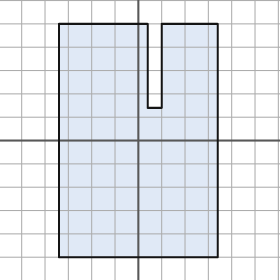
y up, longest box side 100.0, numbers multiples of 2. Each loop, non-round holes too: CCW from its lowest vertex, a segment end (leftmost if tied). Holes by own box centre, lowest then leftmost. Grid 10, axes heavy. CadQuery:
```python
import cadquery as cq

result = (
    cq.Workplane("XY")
    .moveTo(-34.0, -50.0)
    .lineTo(34.0, -50.0)
    .lineTo(34.0, 50.0)
    .lineTo(10.0, 50.0)
    .lineTo(10.0, 14.0)
    .lineTo(4.0, 14.0)
    .lineTo(4.0, 50.0)
    .lineTo(-34.0, 50.0)
    .close()
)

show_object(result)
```